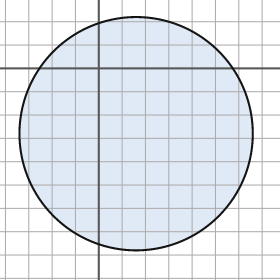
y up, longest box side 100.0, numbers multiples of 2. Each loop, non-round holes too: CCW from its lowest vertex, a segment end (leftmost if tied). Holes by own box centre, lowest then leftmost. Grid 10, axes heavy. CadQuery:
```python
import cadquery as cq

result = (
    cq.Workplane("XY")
    .moveTo(16.0, -28.0)
    .circle(50.0)
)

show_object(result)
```